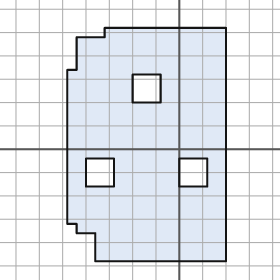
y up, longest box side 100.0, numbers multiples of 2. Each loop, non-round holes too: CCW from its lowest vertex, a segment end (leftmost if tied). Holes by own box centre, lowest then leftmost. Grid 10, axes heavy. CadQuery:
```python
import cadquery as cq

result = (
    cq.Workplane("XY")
    .moveTo(-36.0, -48.0)
    .lineTo(20.0, -48.0)
    .lineTo(20.0, 52.0)
    .lineTo(-32.0, 52.0)
    .lineTo(-32.0, 48.0)
    .lineTo(-44.0, 48.0)
    .lineTo(-44.0, 34.0)
    .lineTo(-48.0, 34.0)
    .lineTo(-48.0, -32.0)
    .lineTo(-44.0, -32.0)
    .lineTo(-44.0, -36.0)
    .lineTo(-36.0, -36.0)
    .close()
    .moveTo(-40.0, -16.0)
    .lineTo(-28.0, -16.0)
    .lineTo(-28.0, -4.0)
    .lineTo(-40.0, -4.0)
    .close()
    .moveTo(0.0, -16.0)
    .lineTo(12.0, -16.0)
    .lineTo(12.0, -4.0)
    .lineTo(0.0, -4.0)
    .close()
    .moveTo(-20.0, 20.0)
    .lineTo(-8.0, 20.0)
    .lineTo(-8.0, 32.0)
    .lineTo(-20.0, 32.0)
    .close()
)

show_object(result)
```